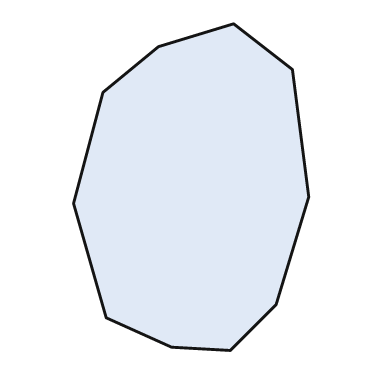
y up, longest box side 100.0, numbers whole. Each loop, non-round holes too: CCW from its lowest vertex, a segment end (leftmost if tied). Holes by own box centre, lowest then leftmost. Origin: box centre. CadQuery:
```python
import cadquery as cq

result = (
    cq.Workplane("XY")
    .moveTo(12.0, -50.0)
    .lineTo(26.0, -36.0)
    .lineTo(36.0, -3.0)
    .lineTo(31.0, 36.0)
    .lineTo(13.0, 50.0)
    .lineTo(-10.0, 43.0)
    .lineTo(-27.0, 29.0)
    .lineTo(-36.0, -5.0)
    .lineTo(-26.0, -40.0)
    .lineTo(-6.0, -49.0)
    .close()
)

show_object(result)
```